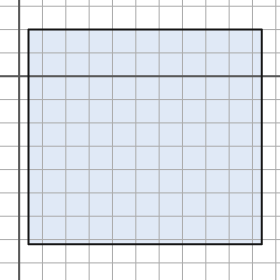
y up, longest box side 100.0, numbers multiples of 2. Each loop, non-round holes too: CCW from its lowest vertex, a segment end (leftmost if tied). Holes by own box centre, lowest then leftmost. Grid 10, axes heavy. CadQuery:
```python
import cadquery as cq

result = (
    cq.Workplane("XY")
    .moveTo(4.0, -72.0)
    .lineTo(104.0, -72.0)
    .lineTo(104.0, 20.0)
    .lineTo(4.0, 20.0)
    .close()
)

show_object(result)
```